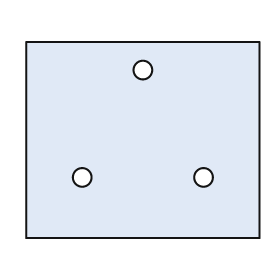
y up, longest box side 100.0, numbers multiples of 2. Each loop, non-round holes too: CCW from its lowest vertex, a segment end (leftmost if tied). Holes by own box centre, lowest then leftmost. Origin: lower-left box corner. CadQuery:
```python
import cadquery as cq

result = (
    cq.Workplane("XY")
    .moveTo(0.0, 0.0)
    .lineTo(100.0, 0.0)
    .lineTo(100.0, 84.0)
    .lineTo(0.0, 84.0)
    .close()
    .moveTo(24.0, 26.0)
    .circle(4.0)
    .moveTo(76.0, 26.0)
    .circle(4.0)
    .moveTo(50.0, 72.0)
    .circle(4.0)
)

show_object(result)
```